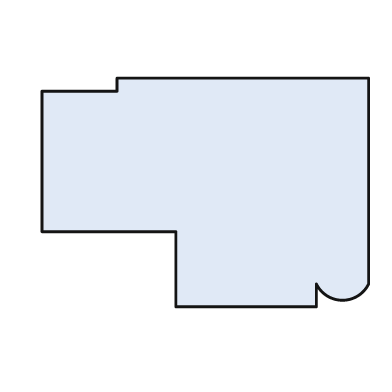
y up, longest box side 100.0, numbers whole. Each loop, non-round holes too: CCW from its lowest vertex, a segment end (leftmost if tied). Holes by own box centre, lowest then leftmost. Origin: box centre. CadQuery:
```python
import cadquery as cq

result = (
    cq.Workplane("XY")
    .moveTo(-9.0, -35.0)
    .lineTo(34.0, -35.0)
    .lineTo(34.0, -28.0)
    .threePointArc((42.0, -33.0), (50.0, -28.0))
    .lineTo(50.0, 35.0)
    .lineTo(-27.0, 35.0)
    .lineTo(-27.0, 31.0)
    .lineTo(-50.0, 31.0)
    .lineTo(-50.0, -12.0)
    .lineTo(-9.0, -12.0)
    .close()
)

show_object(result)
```